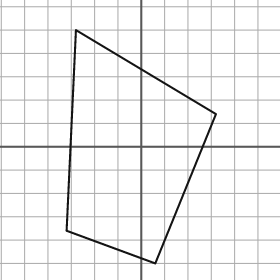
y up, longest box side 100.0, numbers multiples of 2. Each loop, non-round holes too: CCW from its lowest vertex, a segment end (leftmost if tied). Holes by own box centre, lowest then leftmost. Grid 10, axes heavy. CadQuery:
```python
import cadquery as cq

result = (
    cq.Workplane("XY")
    .moveTo(6.0, -50.0)
    .lineTo(32.0, 14.0)
    .lineTo(-28.0, 50.0)
    .lineTo(-32.0, -36.0)
    .close()
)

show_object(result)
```